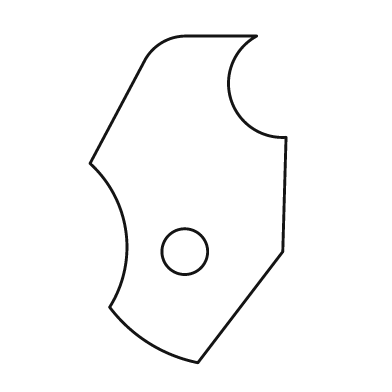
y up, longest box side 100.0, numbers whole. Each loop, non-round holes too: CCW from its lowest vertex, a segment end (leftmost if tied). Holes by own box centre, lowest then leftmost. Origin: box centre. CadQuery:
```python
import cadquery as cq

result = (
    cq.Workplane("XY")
    .moveTo(3.0, -50.0)
    .lineTo(29.0, -16.0)
    .lineTo(30.0, 19.0)
    .threePointArc((13.0, 31.0), (21.0, 50.0))
    .lineTo(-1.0, 50.0)
    .threePointArc((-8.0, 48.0), (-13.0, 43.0))
    .lineTo(-30.0, 11.0)
    .threePointArc((-19.0, -10.0), (-24.0, -33.0))
    .threePointArc((-12.0, -44.0), (3.0, -50.0))
    .close()
    .moveTo(-1.0, -16.0)
    .circle(7.0)
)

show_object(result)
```